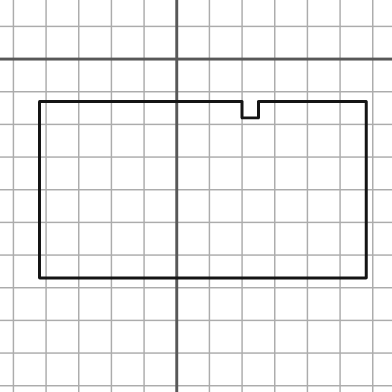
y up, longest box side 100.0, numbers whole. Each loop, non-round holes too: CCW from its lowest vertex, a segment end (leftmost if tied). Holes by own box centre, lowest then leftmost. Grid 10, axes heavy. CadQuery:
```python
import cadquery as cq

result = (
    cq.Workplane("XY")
    .moveTo(-42.0, -67.0)
    .lineTo(58.0, -67.0)
    .lineTo(58.0, -13.0)
    .lineTo(25.0, -13.0)
    .lineTo(25.0, -18.0)
    .lineTo(20.0, -18.0)
    .lineTo(20.0, -13.0)
    .lineTo(-42.0, -13.0)
    .close()
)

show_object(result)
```